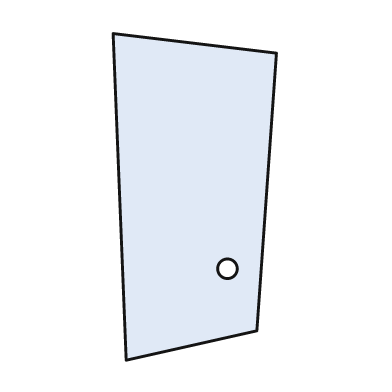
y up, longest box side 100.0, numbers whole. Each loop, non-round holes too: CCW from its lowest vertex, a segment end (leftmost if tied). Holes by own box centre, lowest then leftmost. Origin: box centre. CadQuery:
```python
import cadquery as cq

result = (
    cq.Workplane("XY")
    .moveTo(-21.0, -50.0)
    .lineTo(19.0, -41.0)
    .lineTo(25.0, 44.0)
    .lineTo(-25.0, 50.0)
    .close()
    .moveTo(10.0, -22.0)
    .circle(3.0)
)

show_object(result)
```